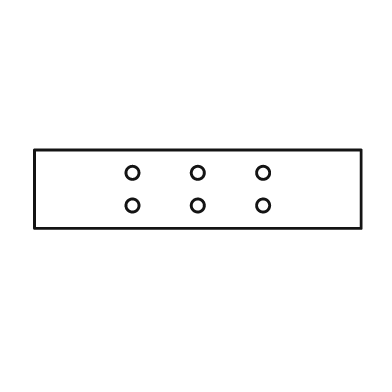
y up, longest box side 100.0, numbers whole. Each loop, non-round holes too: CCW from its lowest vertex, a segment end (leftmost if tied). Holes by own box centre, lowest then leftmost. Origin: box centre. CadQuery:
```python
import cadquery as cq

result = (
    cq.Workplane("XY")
    .moveTo(-50.0, -12.0)
    .lineTo(50.0, -12.0)
    .lineTo(50.0, 12.0)
    .lineTo(-50.0, 12.0)
    .close()
    .moveTo(-20.0, -5.0)
    .circle(2.0)
    .moveTo(0.0, -5.0)
    .circle(2.0)
    .moveTo(20.0, -5.0)
    .circle(2.0)
    .moveTo(-20.0, 5.0)
    .circle(2.0)
    .moveTo(0.0, 5.0)
    .circle(2.0)
    .moveTo(20.0, 5.0)
    .circle(2.0)
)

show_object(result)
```